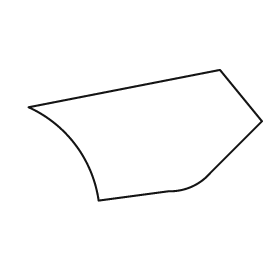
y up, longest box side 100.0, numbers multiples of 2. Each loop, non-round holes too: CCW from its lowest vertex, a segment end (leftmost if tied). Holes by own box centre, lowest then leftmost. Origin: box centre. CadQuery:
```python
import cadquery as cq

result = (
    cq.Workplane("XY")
    .moveTo(-20.0, -28.0)
    .lineTo(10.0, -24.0)
    .threePointArc((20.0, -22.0), (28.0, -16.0))
    .lineTo(50.0, 6.0)
    .lineTo(32.0, 28.0)
    .lineTo(-50.0, 12.0)
    .threePointArc((-30.0, -4.0), (-20.0, -28.0))
    .close()
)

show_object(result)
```